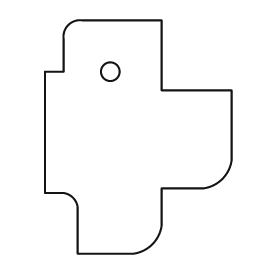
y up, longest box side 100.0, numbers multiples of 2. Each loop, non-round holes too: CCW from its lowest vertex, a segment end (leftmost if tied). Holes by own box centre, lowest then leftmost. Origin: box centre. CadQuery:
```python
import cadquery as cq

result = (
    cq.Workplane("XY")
    .moveTo(-26.0, -50.0)
    .lineTo(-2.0, -50.0)
    .threePointArc((6.0, -46.0), (10.0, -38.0))
    .lineTo(10.0, -22.0)
    .lineTo(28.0, -22.0)
    .threePointArc((36.0, -18.0), (40.0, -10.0))
    .lineTo(40.0, 20.0)
    .lineTo(10.0, 20.0)
    .lineTo(10.0, 50.0)
    .lineTo(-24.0, 50.0)
    .threePointArc((-30.0, 48.0), (-32.0, 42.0))
    .lineTo(-32.0, 28.0)
    .lineTo(-40.0, 28.0)
    .lineTo(-40.0, -24.0)
    .lineTo(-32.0, -24.0)
    .threePointArc((-28.0, -26.0), (-26.0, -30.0))
    .close()
    .moveTo(-12.0, 28.0)
    .circle(4.0)
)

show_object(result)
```